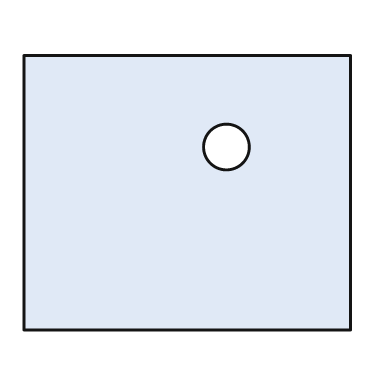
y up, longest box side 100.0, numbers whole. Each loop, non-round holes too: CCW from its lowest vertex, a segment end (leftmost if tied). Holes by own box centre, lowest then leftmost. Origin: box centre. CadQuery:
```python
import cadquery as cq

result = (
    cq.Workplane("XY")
    .moveTo(-50.0, -42.0)
    .lineTo(50.0, -42.0)
    .lineTo(50.0, 42.0)
    .lineTo(-50.0, 42.0)
    .close()
    .moveTo(12.0, 14.0)
    .circle(7.0)
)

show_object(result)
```